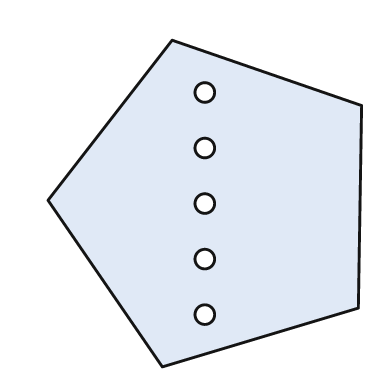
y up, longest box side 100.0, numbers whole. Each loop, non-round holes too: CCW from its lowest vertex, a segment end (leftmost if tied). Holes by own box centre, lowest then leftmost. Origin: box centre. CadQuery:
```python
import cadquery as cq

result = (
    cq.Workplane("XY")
    .moveTo(-13.0, -50.0)
    .lineTo(47.0, -32.0)
    .lineTo(48.0, 30.0)
    .lineTo(-10.0, 50.0)
    .lineTo(-48.0, 1.0)
    .close()
    .moveTo(0.0, -34.0)
    .circle(3.0)
    .moveTo(0.0, -17.0)
    .circle(3.0)
    .moveTo(0.0, 0.0)
    .circle(3.0)
    .moveTo(0.0, 17.0)
    .circle(3.0)
    .moveTo(0.0, 34.0)
    .circle(3.0)
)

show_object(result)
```